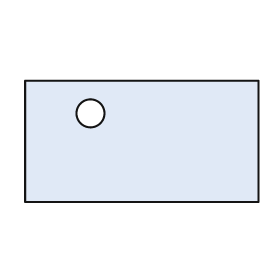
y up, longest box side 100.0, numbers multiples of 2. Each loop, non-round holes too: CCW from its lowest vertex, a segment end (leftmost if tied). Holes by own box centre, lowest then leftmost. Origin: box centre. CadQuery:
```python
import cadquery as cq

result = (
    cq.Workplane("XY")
    .moveTo(-50.0, -26.0)
    .lineTo(50.0, -26.0)
    .lineTo(50.0, 26.0)
    .lineTo(-50.0, 26.0)
    .close()
    .moveTo(-22.0, 12.0)
    .circle(6.0)
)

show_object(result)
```